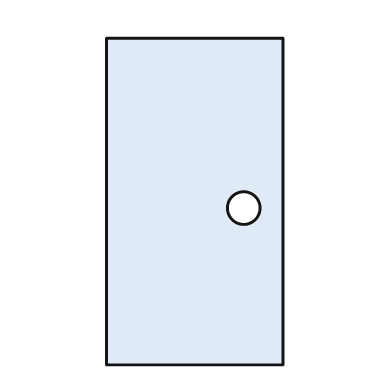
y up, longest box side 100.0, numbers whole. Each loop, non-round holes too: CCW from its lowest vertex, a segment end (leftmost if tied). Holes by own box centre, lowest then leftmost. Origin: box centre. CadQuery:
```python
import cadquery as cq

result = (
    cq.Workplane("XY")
    .moveTo(-27.0, -50.0)
    .lineTo(27.0, -50.0)
    .lineTo(27.0, 50.0)
    .lineTo(-27.0, 50.0)
    .close()
    .moveTo(15.0, -2.0)
    .circle(5.0)
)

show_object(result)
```